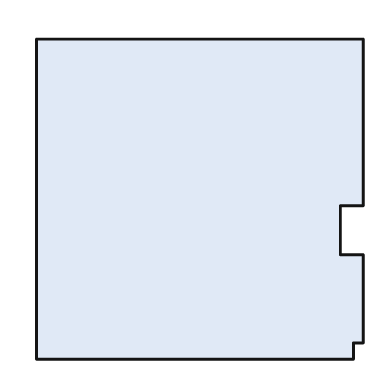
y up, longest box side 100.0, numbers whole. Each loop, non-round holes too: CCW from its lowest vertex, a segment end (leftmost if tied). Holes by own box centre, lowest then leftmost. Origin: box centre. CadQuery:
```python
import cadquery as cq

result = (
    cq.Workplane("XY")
    .moveTo(-50.0, -49.0)
    .lineTo(47.0, -49.0)
    .lineTo(47.0, -44.0)
    .lineTo(50.0, -44.0)
    .lineTo(50.0, -17.0)
    .lineTo(43.0, -17.0)
    .lineTo(43.0, -2.0)
    .lineTo(50.0, -2.0)
    .lineTo(50.0, 49.0)
    .lineTo(-50.0, 49.0)
    .close()
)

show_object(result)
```